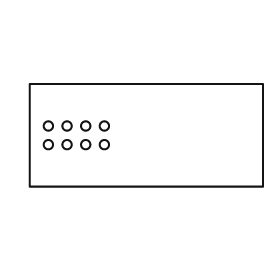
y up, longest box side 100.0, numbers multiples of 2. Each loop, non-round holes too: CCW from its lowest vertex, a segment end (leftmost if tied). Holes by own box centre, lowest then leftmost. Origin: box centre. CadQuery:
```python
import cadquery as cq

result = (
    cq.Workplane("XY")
    .moveTo(-50.0, -22.0)
    .lineTo(50.0, -22.0)
    .lineTo(50.0, 22.0)
    .lineTo(-50.0, 22.0)
    .close()
    .moveTo(-42.0, -4.0)
    .circle(2.0)
    .moveTo(-34.0, -4.0)
    .circle(2.0)
    .moveTo(-26.0, -4.0)
    .circle(2.0)
    .moveTo(-18.0, -4.0)
    .circle(2.0)
    .moveTo(-42.0, 4.0)
    .circle(2.0)
    .moveTo(-34.0, 4.0)
    .circle(2.0)
    .moveTo(-26.0, 4.0)
    .circle(2.0)
    .moveTo(-18.0, 4.0)
    .circle(2.0)
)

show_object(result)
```